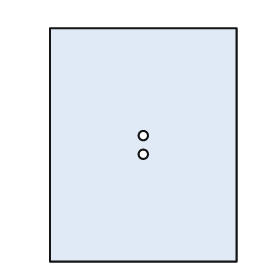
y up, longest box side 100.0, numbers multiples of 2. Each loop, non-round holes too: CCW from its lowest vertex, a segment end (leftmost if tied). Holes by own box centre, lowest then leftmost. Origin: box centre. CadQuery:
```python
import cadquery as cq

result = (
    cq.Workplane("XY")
    .moveTo(-40.0, -50.0)
    .lineTo(40.0, -50.0)
    .lineTo(40.0, 50.0)
    .lineTo(-40.0, 50.0)
    .close()
    .moveTo(0.0, -4.0)
    .circle(2.0)
    .moveTo(0.0, 4.0)
    .circle(2.0)
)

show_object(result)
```